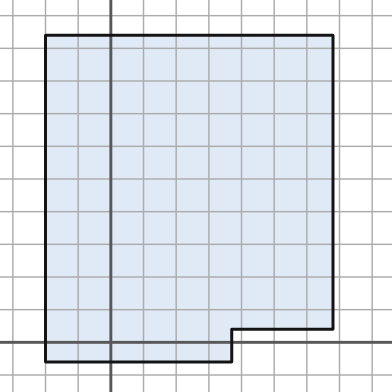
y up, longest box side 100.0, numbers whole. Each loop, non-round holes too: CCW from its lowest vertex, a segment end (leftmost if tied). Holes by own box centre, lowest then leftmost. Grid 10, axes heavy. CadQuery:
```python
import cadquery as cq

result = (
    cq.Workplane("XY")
    .moveTo(-20.0, -6.0)
    .lineTo(37.0, -6.0)
    .lineTo(37.0, 4.0)
    .lineTo(68.0, 4.0)
    .lineTo(68.0, 94.0)
    .lineTo(-20.0, 94.0)
    .close()
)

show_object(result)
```